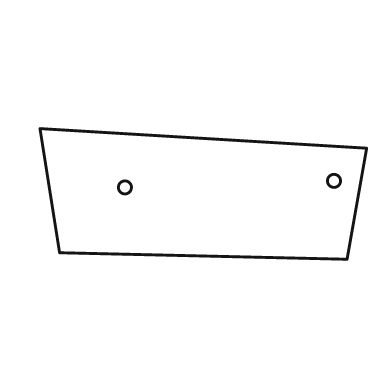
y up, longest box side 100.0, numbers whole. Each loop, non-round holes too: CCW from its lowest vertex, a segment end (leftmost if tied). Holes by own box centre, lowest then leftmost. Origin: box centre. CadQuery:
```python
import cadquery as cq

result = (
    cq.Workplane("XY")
    .moveTo(44.0, -20.0)
    .lineTo(50.0, 14.0)
    .lineTo(-50.0, 20.0)
    .lineTo(-44.0, -18.0)
    .close()
    .moveTo(-24.0, 2.0)
    .circle(2.0)
    .moveTo(40.0, 4.0)
    .circle(2.0)
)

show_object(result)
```